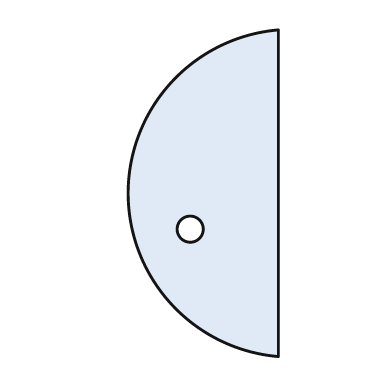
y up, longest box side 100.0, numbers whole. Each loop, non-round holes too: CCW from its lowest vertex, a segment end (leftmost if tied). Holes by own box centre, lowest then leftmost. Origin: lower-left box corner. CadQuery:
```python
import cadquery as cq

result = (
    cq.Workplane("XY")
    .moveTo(46.0, 0.0)
    .lineTo(46.0, 100.0)
    .threePointArc((0.0, 50.0), (46.0, 0.0))
    .close()
    .moveTo(19.0, 39.0)
    .circle(4.0)
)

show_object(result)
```